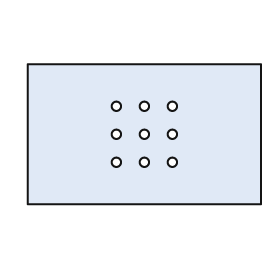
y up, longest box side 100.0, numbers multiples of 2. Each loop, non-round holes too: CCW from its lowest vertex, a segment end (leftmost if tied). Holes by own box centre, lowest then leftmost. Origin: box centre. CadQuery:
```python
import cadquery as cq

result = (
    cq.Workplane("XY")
    .moveTo(-50.0, -30.0)
    .lineTo(50.0, -30.0)
    .lineTo(50.0, 30.0)
    .lineTo(-50.0, 30.0)
    .close()
    .moveTo(-12.0, -12.0)
    .circle(2.0)
    .moveTo(0.0, -12.0)
    .circle(2.0)
    .moveTo(12.0, -12.0)
    .circle(2.0)
    .moveTo(-12.0, 0.0)
    .circle(2.0)
    .moveTo(0.0, 0.0)
    .circle(2.0)
    .moveTo(12.0, 0.0)
    .circle(2.0)
    .moveTo(-12.0, 12.0)
    .circle(2.0)
    .moveTo(0.0, 12.0)
    .circle(2.0)
    .moveTo(12.0, 12.0)
    .circle(2.0)
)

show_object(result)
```